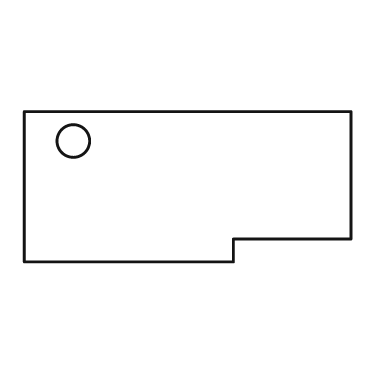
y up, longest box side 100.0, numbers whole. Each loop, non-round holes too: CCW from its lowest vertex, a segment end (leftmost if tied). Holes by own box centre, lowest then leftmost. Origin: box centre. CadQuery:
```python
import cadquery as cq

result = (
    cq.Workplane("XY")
    .moveTo(-50.0, -23.0)
    .lineTo(14.0, -23.0)
    .lineTo(14.0, -16.0)
    .lineTo(50.0, -16.0)
    .lineTo(50.0, 23.0)
    .lineTo(-50.0, 23.0)
    .close()
    .moveTo(-35.0, 14.0)
    .circle(5.0)
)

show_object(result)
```